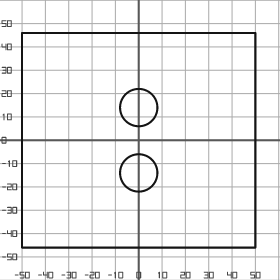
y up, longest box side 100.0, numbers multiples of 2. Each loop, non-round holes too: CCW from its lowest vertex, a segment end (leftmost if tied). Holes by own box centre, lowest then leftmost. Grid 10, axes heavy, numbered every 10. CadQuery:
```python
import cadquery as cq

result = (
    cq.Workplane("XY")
    .moveTo(-50.0, -46.0)
    .lineTo(50.0, -46.0)
    .lineTo(50.0, 46.0)
    .lineTo(-50.0, 46.0)
    .close()
    .moveTo(0.0, -14.0)
    .circle(8.0)
    .moveTo(0.0, 14.0)
    .circle(8.0)
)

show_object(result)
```